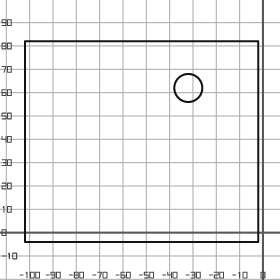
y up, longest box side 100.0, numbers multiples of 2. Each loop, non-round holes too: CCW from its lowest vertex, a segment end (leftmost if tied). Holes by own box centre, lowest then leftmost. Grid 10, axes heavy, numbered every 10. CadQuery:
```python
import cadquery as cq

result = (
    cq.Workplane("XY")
    .moveTo(-102.0, -4.0)
    .lineTo(-2.0, -4.0)
    .lineTo(-2.0, 82.0)
    .lineTo(-102.0, 82.0)
    .close()
    .moveTo(-32.0, 62.0)
    .circle(6.0)
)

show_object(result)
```